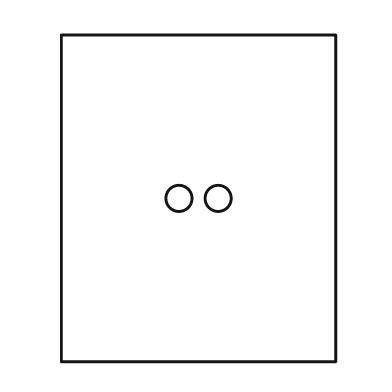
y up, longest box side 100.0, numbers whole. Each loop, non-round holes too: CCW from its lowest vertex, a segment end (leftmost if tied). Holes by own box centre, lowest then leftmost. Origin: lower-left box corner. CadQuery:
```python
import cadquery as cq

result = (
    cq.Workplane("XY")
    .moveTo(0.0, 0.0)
    .lineTo(84.0, 0.0)
    .lineTo(84.0, 100.0)
    .lineTo(0.0, 100.0)
    .close()
    .moveTo(36.0, 50.0)
    .circle(4.0)
    .moveTo(48.0, 50.0)
    .circle(4.0)
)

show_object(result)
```